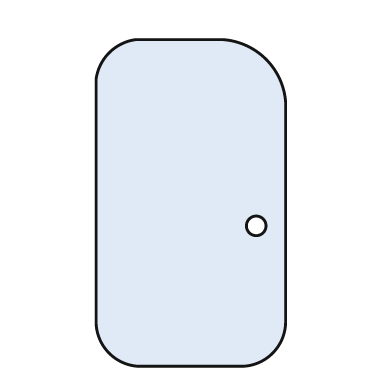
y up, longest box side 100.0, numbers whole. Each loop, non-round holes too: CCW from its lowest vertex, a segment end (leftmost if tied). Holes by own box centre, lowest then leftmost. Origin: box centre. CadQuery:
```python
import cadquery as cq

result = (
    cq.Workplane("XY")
    .moveTo(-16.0, -50.0)
    .lineTo(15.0, -50.0)
    .threePointArc((25.0, -46.0), (29.0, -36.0))
    .lineTo(29.0, 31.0)
    .threePointArc((23.0, 44.0), (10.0, 50.0))
    .lineTo(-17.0, 50.0)
    .threePointArc((-25.0, 46.0), (-29.0, 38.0))
    .lineTo(-29.0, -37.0)
    .threePointArc((-25.0, -46.0), (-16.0, -50.0))
    .close()
    .moveTo(20.0, -7.0)
    .circle(3.0)
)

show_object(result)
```